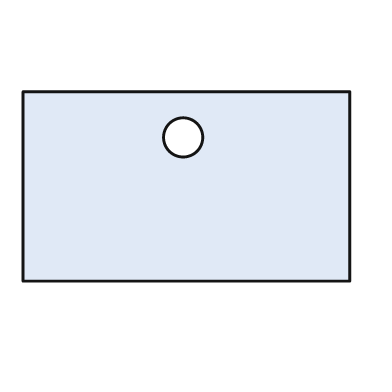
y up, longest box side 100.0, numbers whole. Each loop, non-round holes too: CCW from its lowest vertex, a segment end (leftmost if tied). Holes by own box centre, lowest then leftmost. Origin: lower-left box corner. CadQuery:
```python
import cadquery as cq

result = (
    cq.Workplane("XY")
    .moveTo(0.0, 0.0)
    .lineTo(100.0, 0.0)
    .lineTo(100.0, 58.0)
    .lineTo(0.0, 58.0)
    .close()
    .moveTo(49.0, 44.0)
    .circle(6.0)
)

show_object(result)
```